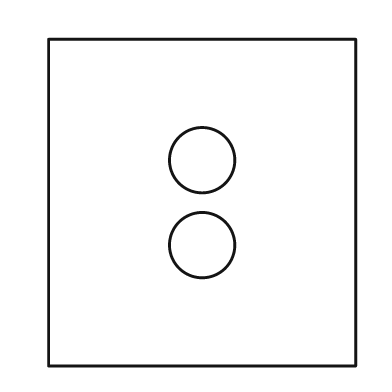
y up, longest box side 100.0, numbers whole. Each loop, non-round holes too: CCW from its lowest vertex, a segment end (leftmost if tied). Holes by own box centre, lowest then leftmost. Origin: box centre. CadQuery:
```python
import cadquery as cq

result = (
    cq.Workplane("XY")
    .moveTo(-47.0, -50.0)
    .lineTo(47.0, -50.0)
    .lineTo(47.0, 50.0)
    .lineTo(-47.0, 50.0)
    .close()
    .moveTo(0.0, -13.0)
    .circle(10.0)
    .moveTo(0.0, 13.0)
    .circle(10.0)
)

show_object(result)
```